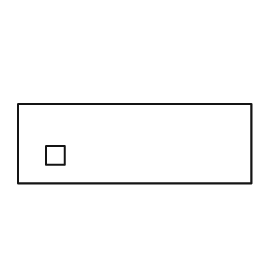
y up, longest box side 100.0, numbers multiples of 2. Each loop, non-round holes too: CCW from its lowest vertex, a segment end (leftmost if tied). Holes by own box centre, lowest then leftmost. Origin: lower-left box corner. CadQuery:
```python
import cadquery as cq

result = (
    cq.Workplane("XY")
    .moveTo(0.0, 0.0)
    .lineTo(100.0, 0.0)
    .lineTo(100.0, 34.0)
    .lineTo(0.0, 34.0)
    .close()
    .moveTo(12.0, 8.0)
    .lineTo(20.0, 8.0)
    .lineTo(20.0, 16.0)
    .lineTo(12.0, 16.0)
    .close()
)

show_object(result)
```